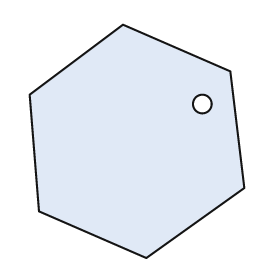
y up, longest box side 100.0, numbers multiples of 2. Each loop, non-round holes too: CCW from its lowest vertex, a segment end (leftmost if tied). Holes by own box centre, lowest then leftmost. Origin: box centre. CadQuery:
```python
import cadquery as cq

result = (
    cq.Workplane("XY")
    .moveTo(4.0, -50.0)
    .lineTo(46.0, -20.0)
    .lineTo(40.0, 30.0)
    .lineTo(-6.0, 50.0)
    .lineTo(-46.0, 20.0)
    .lineTo(-42.0, -30.0)
    .close()
    .moveTo(28.0, 16.0)
    .circle(4.0)
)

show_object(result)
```